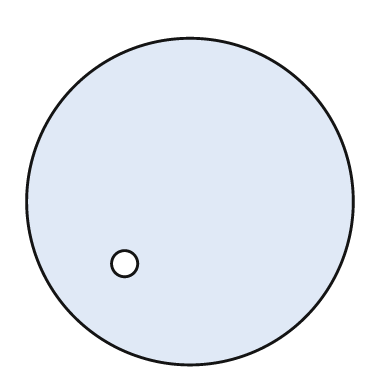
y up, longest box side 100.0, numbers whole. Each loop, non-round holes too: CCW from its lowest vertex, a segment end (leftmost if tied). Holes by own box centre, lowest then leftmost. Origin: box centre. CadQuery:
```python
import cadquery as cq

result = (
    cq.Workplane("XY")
    .moveTo(0.0, 0.0)
    .circle(50.0)
    .moveTo(-20.0, -19.0)
    .circle(4.0)
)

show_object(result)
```